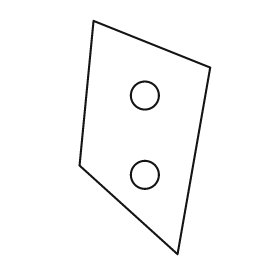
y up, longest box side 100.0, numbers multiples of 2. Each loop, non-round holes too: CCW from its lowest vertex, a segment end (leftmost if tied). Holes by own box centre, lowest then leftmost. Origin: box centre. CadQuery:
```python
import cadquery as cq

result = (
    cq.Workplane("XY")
    .moveTo(14.0, -50.0)
    .lineTo(28.0, 30.0)
    .lineTo(-22.0, 50.0)
    .lineTo(-28.0, -12.0)
    .close()
    .moveTo(0.0, -16.0)
    .circle(6.0)
    .moveTo(0.0, 18.0)
    .circle(6.0)
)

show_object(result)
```